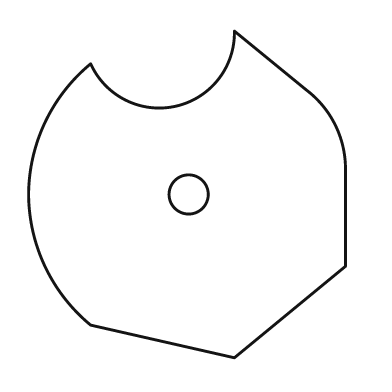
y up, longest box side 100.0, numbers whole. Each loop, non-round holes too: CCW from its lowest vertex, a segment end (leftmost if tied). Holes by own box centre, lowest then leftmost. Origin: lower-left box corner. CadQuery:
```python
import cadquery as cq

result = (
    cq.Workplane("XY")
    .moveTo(63.0, 0.0)
    .lineTo(97.0, 28.0)
    .lineTo(97.0, 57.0)
    .threePointArc((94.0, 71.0), (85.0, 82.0))
    .lineTo(63.0, 100.0)
    .threePointArc((45.0, 77.0), (19.0, 90.0))
    .threePointArc((5.0, 72.0), (0.0, 50.0))
    .threePointArc((5.0, 28.0), (19.0, 10.0))
    .close()
    .moveTo(49.0, 50.0)
    .circle(6.0)
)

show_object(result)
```